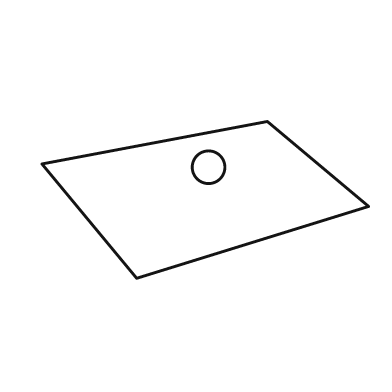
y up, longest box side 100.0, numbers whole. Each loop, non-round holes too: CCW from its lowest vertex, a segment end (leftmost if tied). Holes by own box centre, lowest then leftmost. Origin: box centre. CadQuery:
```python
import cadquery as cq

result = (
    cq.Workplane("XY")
    .moveTo(-21.0, -24.0)
    .lineTo(50.0, -2.0)
    .lineTo(19.0, 24.0)
    .lineTo(-50.0, 11.0)
    .close()
    .moveTo(1.0, 10.0)
    .circle(5.0)
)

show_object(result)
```